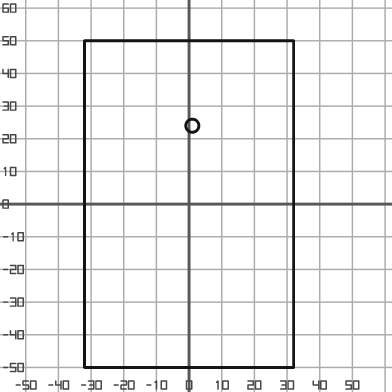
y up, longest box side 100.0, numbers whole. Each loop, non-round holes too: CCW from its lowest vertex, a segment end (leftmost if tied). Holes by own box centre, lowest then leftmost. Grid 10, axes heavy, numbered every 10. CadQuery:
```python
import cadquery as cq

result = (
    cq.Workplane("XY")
    .moveTo(-32.0, -50.0)
    .lineTo(32.0, -50.0)
    .lineTo(32.0, 50.0)
    .lineTo(-32.0, 50.0)
    .close()
    .moveTo(1.0, 24.0)
    .circle(2.0)
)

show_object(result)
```